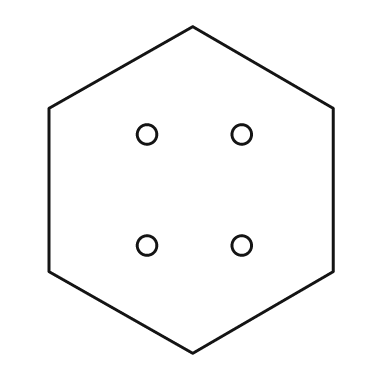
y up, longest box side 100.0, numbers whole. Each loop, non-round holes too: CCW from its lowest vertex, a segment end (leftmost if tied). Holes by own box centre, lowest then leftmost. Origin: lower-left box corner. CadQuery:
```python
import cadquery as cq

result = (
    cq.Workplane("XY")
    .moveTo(44.0, 0.0)
    .lineTo(87.0, 25.0)
    .lineTo(87.0, 75.0)
    .lineTo(44.0, 100.0)
    .lineTo(0.0, 75.0)
    .lineTo(0.0, 25.0)
    .close()
    .moveTo(30.0, 33.0)
    .circle(3.0)
    .moveTo(59.0, 33.0)
    .circle(3.0)
    .moveTo(30.0, 67.0)
    .circle(3.0)
    .moveTo(59.0, 67.0)
    .circle(3.0)
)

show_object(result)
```